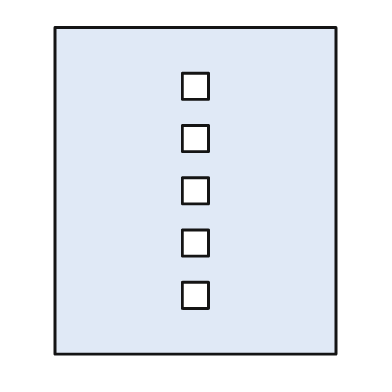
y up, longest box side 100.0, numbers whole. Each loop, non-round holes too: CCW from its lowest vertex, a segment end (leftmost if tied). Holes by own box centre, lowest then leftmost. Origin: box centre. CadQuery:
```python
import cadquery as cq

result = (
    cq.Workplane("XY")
    .moveTo(-43.0, -50.0)
    .lineTo(43.0, -50.0)
    .lineTo(43.0, 50.0)
    .lineTo(-43.0, 50.0)
    .close()
    .moveTo(-4.0, -36.0)
    .lineTo(4.0, -36.0)
    .lineTo(4.0, -28.0)
    .lineTo(-4.0, -28.0)
    .close()
    .moveTo(-4.0, -20.0)
    .lineTo(4.0, -20.0)
    .lineTo(4.0, -12.0)
    .lineTo(-4.0, -12.0)
    .close()
    .moveTo(-4.0, -4.0)
    .lineTo(4.0, -4.0)
    .lineTo(4.0, 4.0)
    .lineTo(-4.0, 4.0)
    .close()
    .moveTo(-4.0, 12.0)
    .lineTo(4.0, 12.0)
    .lineTo(4.0, 20.0)
    .lineTo(-4.0, 20.0)
    .close()
    .moveTo(-4.0, 28.0)
    .lineTo(4.0, 28.0)
    .lineTo(4.0, 36.0)
    .lineTo(-4.0, 36.0)
    .close()
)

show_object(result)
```